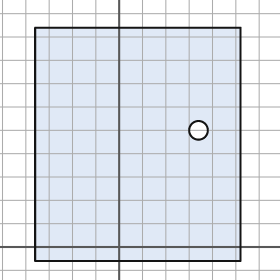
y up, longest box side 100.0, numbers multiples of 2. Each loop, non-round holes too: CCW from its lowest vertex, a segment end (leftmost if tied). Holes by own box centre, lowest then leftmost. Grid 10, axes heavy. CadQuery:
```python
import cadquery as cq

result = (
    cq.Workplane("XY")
    .moveTo(-36.0, -6.0)
    .lineTo(52.0, -6.0)
    .lineTo(52.0, 94.0)
    .lineTo(-36.0, 94.0)
    .close()
    .moveTo(34.0, 50.0)
    .circle(4.0)
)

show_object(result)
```